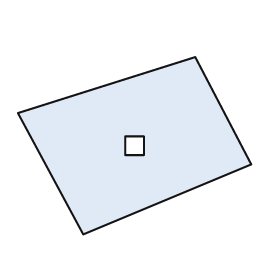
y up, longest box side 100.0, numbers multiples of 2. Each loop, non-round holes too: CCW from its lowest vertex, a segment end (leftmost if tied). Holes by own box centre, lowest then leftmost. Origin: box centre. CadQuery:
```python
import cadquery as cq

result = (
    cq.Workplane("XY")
    .moveTo(-22.0, -38.0)
    .lineTo(50.0, -8.0)
    .lineTo(26.0, 38.0)
    .lineTo(-50.0, 14.0)
    .close()
    .moveTo(-4.0, -4.0)
    .lineTo(4.0, -4.0)
    .lineTo(4.0, 4.0)
    .lineTo(-4.0, 4.0)
    .close()
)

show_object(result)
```